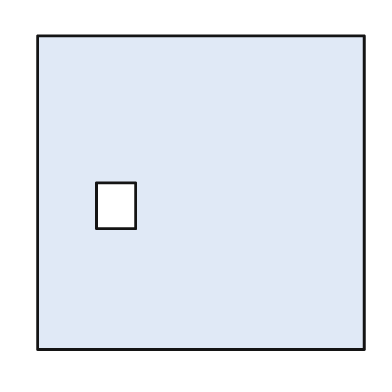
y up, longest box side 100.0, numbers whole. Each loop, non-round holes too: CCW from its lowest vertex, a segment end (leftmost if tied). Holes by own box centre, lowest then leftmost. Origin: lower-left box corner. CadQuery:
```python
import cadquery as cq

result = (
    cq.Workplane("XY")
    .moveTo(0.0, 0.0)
    .lineTo(100.0, 0.0)
    .lineTo(100.0, 96.0)
    .lineTo(0.0, 96.0)
    .close()
    .moveTo(18.0, 37.0)
    .lineTo(30.0, 37.0)
    .lineTo(30.0, 51.0)
    .lineTo(18.0, 51.0)
    .close()
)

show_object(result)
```